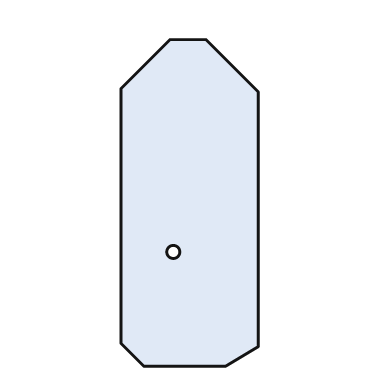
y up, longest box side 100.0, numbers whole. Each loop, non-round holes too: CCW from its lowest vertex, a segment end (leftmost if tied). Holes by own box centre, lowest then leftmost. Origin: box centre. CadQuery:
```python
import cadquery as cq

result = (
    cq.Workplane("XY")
    .moveTo(-14.0, -50.0)
    .lineTo(11.0, -50.0)
    .lineTo(21.0, -44.0)
    .lineTo(21.0, 34.0)
    .lineTo(5.0, 50.0)
    .lineTo(-6.0, 50.0)
    .lineTo(-21.0, 35.0)
    .lineTo(-21.0, -43.0)
    .close()
    .moveTo(-5.0, -15.0)
    .circle(2.0)
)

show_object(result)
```